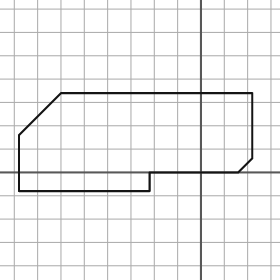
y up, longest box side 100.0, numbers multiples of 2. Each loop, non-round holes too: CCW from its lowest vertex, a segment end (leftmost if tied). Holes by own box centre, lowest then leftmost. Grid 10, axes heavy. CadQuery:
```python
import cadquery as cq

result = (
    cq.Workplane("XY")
    .moveTo(-78.0, -8.0)
    .lineTo(-22.0, -8.0)
    .lineTo(-22.0, 0.0)
    .lineTo(16.0, 0.0)
    .lineTo(22.0, 6.0)
    .lineTo(22.0, 34.0)
    .lineTo(-60.0, 34.0)
    .lineTo(-78.0, 16.0)
    .close()
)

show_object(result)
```